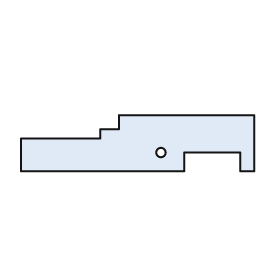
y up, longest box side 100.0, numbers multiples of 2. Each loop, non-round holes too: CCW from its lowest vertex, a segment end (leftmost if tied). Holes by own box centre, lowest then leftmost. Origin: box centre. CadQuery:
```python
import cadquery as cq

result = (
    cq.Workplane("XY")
    .moveTo(-50.0, -12.0)
    .lineTo(20.0, -12.0)
    .lineTo(20.0, -4.0)
    .lineTo(44.0, -4.0)
    .lineTo(44.0, -12.0)
    .lineTo(50.0, -12.0)
    .lineTo(50.0, 12.0)
    .lineTo(-8.0, 12.0)
    .lineTo(-8.0, 6.0)
    .lineTo(-16.0, 6.0)
    .lineTo(-16.0, 2.0)
    .lineTo(-50.0, 2.0)
    .close()
    .moveTo(10.0, -4.0)
    .circle(2.0)
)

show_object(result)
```